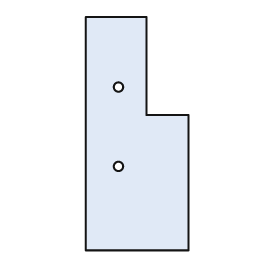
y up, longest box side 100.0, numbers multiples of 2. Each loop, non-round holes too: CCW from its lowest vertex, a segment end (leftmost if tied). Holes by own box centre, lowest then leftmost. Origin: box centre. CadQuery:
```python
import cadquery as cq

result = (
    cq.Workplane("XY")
    .moveTo(-22.0, -50.0)
    .lineTo(22.0, -50.0)
    .lineTo(22.0, 8.0)
    .lineTo(4.0, 8.0)
    .lineTo(4.0, 50.0)
    .lineTo(-22.0, 50.0)
    .close()
    .moveTo(-8.0, -14.0)
    .circle(2.0)
    .moveTo(-8.0, 20.0)
    .circle(2.0)
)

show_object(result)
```